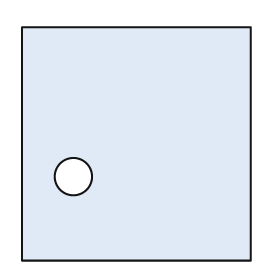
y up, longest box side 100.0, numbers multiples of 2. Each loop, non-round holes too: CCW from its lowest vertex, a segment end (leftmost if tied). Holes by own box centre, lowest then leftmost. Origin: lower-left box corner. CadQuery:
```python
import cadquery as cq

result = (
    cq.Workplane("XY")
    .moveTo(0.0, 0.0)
    .lineTo(98.0, 0.0)
    .lineTo(98.0, 100.0)
    .lineTo(0.0, 100.0)
    .close()
    .moveTo(22.0, 36.0)
    .circle(8.0)
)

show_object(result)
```